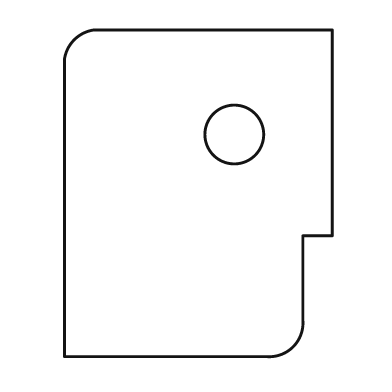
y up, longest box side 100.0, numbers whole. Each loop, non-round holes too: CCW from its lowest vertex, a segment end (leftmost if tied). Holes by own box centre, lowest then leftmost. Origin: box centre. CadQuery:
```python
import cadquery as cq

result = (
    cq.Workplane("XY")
    .moveTo(-41.0, -50.0)
    .lineTo(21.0, -50.0)
    .threePointArc((29.0, -47.0), (32.0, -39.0))
    .lineTo(32.0, -13.0)
    .lineTo(41.0, -13.0)
    .lineTo(41.0, 50.0)
    .lineTo(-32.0, 50.0)
    .threePointArc((-38.0, 47.0), (-41.0, 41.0))
    .close()
    .moveTo(11.0, 18.0)
    .circle(9.0)
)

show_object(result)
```